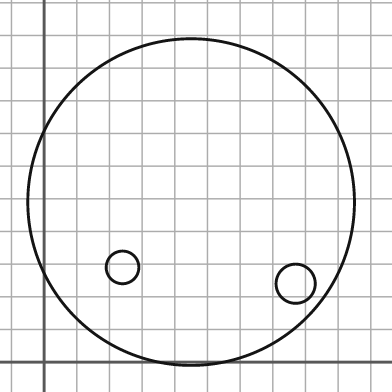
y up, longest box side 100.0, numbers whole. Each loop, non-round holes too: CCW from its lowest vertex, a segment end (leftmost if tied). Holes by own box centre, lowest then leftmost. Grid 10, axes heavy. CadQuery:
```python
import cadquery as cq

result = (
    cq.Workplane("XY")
    .moveTo(45.0, 49.0)
    .circle(50.0)
    .moveTo(77.0, 24.0)
    .circle(6.0)
    .moveTo(24.0, 29.0)
    .circle(5.0)
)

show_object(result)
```